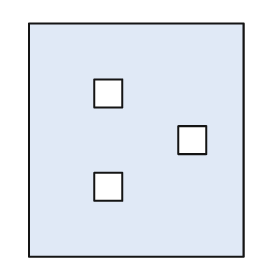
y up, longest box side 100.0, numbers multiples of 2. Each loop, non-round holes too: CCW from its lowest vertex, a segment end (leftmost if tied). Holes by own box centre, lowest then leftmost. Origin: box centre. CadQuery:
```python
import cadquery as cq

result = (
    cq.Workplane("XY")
    .moveTo(-46.0, -50.0)
    .lineTo(46.0, -50.0)
    .lineTo(46.0, 50.0)
    .lineTo(-46.0, 50.0)
    .close()
    .moveTo(-18.0, -26.0)
    .lineTo(-6.0, -26.0)
    .lineTo(-6.0, -14.0)
    .lineTo(-18.0, -14.0)
    .close()
    .moveTo(18.0, -6.0)
    .lineTo(30.0, -6.0)
    .lineTo(30.0, 6.0)
    .lineTo(18.0, 6.0)
    .close()
    .moveTo(-18.0, 14.0)
    .lineTo(-6.0, 14.0)
    .lineTo(-6.0, 26.0)
    .lineTo(-18.0, 26.0)
    .close()
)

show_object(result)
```